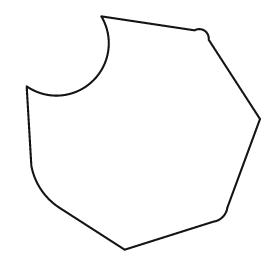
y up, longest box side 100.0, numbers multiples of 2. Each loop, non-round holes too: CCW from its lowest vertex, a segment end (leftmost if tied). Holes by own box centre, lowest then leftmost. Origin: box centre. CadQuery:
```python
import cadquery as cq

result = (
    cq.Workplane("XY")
    .moveTo(-8.0, -50.0)
    .lineTo(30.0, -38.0)
    .threePointArc((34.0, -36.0), (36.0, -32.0))
    .lineTo(50.0, 6.0)
    .lineTo(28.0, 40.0)
    .threePointArc((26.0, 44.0), (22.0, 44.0))
    .lineTo(-18.0, 50.0)
    .threePointArc((-22.0, 22.0), (-50.0, 20.0))
    .lineTo(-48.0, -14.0)
    .threePointArc((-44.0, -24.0), (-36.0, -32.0))
    .close()
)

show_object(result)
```